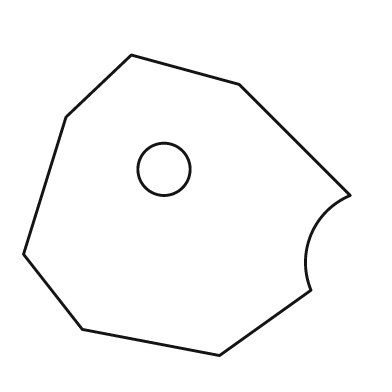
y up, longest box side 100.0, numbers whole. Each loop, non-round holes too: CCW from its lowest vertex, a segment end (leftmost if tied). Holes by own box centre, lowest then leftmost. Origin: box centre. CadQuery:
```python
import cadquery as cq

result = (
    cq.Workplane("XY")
    .moveTo(10.0, -46.0)
    .lineTo(38.0, -26.0)
    .threePointArc((38.0, -9.0), (50.0, 3.0))
    .lineTo(16.0, 37.0)
    .lineTo(-17.0, 46.0)
    .lineTo(-37.0, 27.0)
    .lineTo(-50.0, -15.0)
    .lineTo(-32.0, -38.0)
    .close()
    .moveTo(-7.0, 11.0)
    .circle(8.0)
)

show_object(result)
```